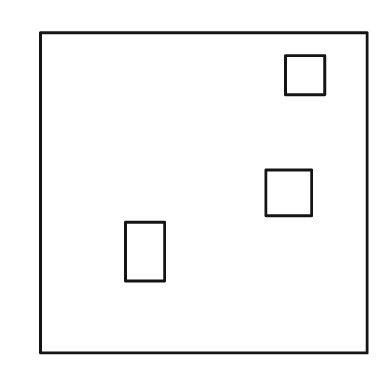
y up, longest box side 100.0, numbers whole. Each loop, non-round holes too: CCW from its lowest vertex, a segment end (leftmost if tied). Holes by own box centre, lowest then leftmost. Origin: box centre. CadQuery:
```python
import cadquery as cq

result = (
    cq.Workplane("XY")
    .moveTo(-50.0, -49.0)
    .lineTo(50.0, -49.0)
    .lineTo(50.0, 49.0)
    .lineTo(-50.0, 49.0)
    .close()
    .moveTo(-24.0, -27.0)
    .lineTo(-12.0, -27.0)
    .lineTo(-12.0, -9.0)
    .lineTo(-24.0, -9.0)
    .close()
    .moveTo(19.0, -7.0)
    .lineTo(33.0, -7.0)
    .lineTo(33.0, 7.0)
    .lineTo(19.0, 7.0)
    .close()
    .moveTo(25.0, 30.0)
    .lineTo(37.0, 30.0)
    .lineTo(37.0, 42.0)
    .lineTo(25.0, 42.0)
    .close()
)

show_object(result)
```